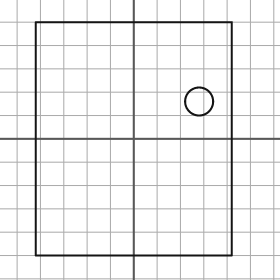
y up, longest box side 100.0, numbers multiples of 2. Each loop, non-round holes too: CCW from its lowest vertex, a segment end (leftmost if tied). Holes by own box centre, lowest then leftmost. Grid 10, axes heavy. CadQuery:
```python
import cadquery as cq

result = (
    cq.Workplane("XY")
    .moveTo(-42.0, -50.0)
    .lineTo(42.0, -50.0)
    .lineTo(42.0, 50.0)
    .lineTo(-42.0, 50.0)
    .close()
    .moveTo(28.0, 16.0)
    .circle(6.0)
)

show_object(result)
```